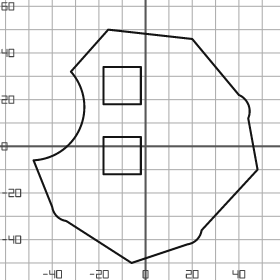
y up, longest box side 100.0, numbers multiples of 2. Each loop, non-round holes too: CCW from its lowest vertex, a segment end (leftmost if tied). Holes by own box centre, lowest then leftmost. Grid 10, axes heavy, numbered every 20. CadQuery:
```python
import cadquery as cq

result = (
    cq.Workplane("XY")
    .moveTo(-6.0, -50.0)
    .lineTo(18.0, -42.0)
    .threePointArc((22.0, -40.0), (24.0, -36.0))
    .lineTo(48.0, -10.0)
    .lineTo(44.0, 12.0)
    .threePointArc((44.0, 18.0), (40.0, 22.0))
    .lineTo(20.0, 46.0)
    .lineTo(-16.0, 50.0)
    .lineTo(-32.0, 32.0)
    .threePointArc((-28.0, 8.0), (-48.0, -6.0))
    .lineTo(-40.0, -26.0)
    .threePointArc((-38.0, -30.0), (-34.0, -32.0))
    .close()
    .moveTo(-18.0, -12.0)
    .lineTo(-2.0, -12.0)
    .lineTo(-2.0, 4.0)
    .lineTo(-18.0, 4.0)
    .close()
    .moveTo(-18.0, 18.0)
    .lineTo(-2.0, 18.0)
    .lineTo(-2.0, 34.0)
    .lineTo(-18.0, 34.0)
    .close()
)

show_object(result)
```